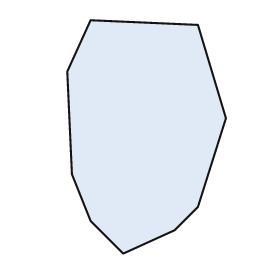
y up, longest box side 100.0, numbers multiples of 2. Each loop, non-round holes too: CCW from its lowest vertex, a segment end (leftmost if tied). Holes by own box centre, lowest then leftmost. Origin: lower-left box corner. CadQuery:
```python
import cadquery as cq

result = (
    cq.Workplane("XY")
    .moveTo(24.0, 0.0)
    .lineTo(46.0, 10.0)
    .lineTo(56.0, 20.0)
    .lineTo(68.0, 58.0)
    .lineTo(56.0, 98.0)
    .lineTo(10.0, 100.0)
    .lineTo(0.0, 78.0)
    .lineTo(2.0, 34.0)
    .lineTo(10.0, 14.0)
    .close()
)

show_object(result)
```